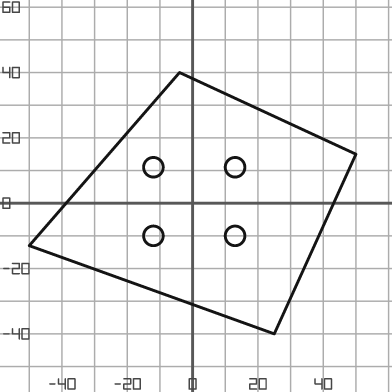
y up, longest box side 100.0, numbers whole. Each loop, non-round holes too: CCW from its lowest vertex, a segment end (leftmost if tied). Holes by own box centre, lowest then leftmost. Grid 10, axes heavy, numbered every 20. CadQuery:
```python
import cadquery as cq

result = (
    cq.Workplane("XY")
    .moveTo(25.0, -40.0)
    .lineTo(50.0, 15.0)
    .lineTo(-4.0, 40.0)
    .lineTo(-50.0, -13.0)
    .close()
    .moveTo(-12.0, -10.0)
    .circle(3.0)
    .moveTo(13.0, -10.0)
    .circle(3.0)
    .moveTo(-12.0, 11.0)
    .circle(3.0)
    .moveTo(13.0, 11.0)
    .circle(3.0)
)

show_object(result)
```